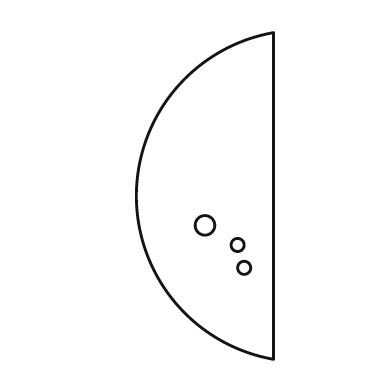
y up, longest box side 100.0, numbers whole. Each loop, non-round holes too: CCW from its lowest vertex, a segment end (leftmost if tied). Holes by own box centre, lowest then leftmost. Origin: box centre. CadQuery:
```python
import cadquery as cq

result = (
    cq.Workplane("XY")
    .moveTo(21.0, -50.0)
    .lineTo(21.0, 50.0)
    .threePointArc((-21.0, 0.0), (21.0, -50.0))
    .close()
    .moveTo(12.0, -22.0)
    .circle(2.0)
    .moveTo(10.0, -15.0)
    .circle(2.0)
    .moveTo(0.0, -9.0)
    .circle(3.0)
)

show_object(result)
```